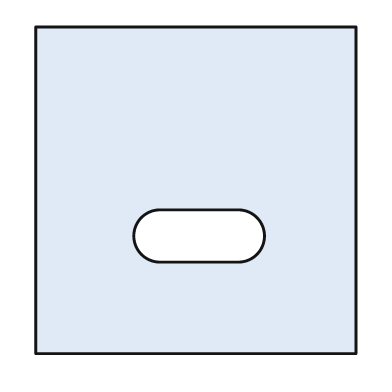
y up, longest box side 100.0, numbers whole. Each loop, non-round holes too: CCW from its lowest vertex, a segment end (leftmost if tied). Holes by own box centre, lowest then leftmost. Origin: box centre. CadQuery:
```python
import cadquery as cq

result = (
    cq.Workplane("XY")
    .moveTo(-49.0, -50.0)
    .lineTo(49.0, -50.0)
    .lineTo(49.0, 50.0)
    .lineTo(-49.0, 50.0)
    .close()
    .moveTo(-11.0, -22.0)
    .lineTo(13.0, -22.0)
    .threePointArc((21.0, -14.0), (13.0, -6.0))
    .lineTo(-11.0, -6.0)
    .threePointArc((-19.0, -14.0), (-11.0, -22.0))
    .close()
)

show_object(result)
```